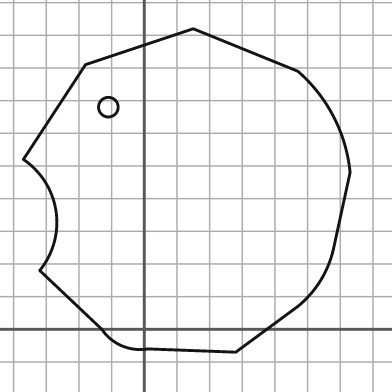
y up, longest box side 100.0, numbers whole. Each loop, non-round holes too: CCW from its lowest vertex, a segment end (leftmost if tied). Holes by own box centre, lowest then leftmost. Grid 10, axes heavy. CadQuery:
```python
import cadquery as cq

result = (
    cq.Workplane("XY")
    .moveTo(28.0, -7.0)
    .lineTo(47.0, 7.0)
    .threePointArc((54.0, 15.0), (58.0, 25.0))
    .lineTo(63.0, 48.0)
    .threePointArc((58.0, 65.0), (47.0, 79.0))
    .lineTo(15.0, 92.0)
    .lineTo(-18.0, 81.0)
    .lineTo(-37.0, 52.0)
    .threePointArc((-27.0, 36.0), (-32.0, 18.0))
    .lineTo(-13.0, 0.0)
    .threePointArc((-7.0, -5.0), (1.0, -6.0))
    .close()
    .moveTo(-11.0, 68.0)
    .circle(3.0)
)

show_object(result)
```